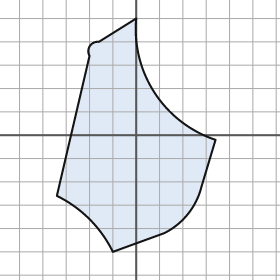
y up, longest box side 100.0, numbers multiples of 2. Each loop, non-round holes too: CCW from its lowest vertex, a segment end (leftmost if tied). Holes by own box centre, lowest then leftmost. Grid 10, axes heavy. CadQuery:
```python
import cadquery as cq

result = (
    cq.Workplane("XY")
    .moveTo(-10.0, -50.0)
    .lineTo(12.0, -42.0)
    .threePointArc((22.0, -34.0), (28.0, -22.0))
    .lineTo(34.0, -2.0)
    .threePointArc((8.0, 18.0), (0.0, 50.0))
    .lineTo(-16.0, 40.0)
    .threePointArc((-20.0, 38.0), (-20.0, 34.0))
    .lineTo(-34.0, -26.0)
    .threePointArc((-20.0, -36.0), (-10.0, -50.0))
    .close()
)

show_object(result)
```